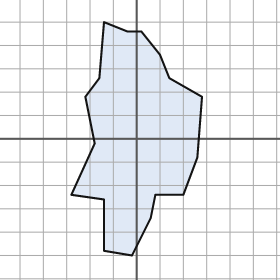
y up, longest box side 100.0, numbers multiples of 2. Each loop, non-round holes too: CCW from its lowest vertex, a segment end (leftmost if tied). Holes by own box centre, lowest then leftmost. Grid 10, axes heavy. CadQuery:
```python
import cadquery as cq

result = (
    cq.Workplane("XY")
    .moveTo(-2.0, -50.0)
    .lineTo(6.0, -34.0)
    .lineTo(8.0, -24.0)
    .lineTo(20.0, -24.0)
    .lineTo(26.0, -8.0)
    .lineTo(28.0, 18.0)
    .lineTo(14.0, 26.0)
    .lineTo(10.0, 36.0)
    .lineTo(2.0, 46.0)
    .lineTo(-4.0, 46.0)
    .lineTo(-14.0, 50.0)
    .lineTo(-16.0, 26.0)
    .lineTo(-22.0, 18.0)
    .lineTo(-18.0, -2.0)
    .lineTo(-28.0, -24.0)
    .lineTo(-14.0, -26.0)
    .lineTo(-14.0, -48.0)
    .close()
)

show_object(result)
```